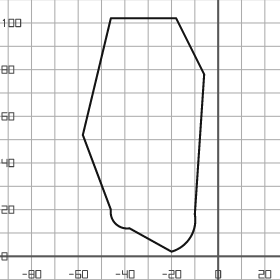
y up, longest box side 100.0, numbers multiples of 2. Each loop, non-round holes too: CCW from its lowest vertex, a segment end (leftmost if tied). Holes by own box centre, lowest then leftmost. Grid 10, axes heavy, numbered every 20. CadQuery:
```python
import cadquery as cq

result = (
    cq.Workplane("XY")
    .moveTo(-20.0, 2.0)
    .threePointArc((-12.0, 8.0), (-10.0, 18.0))
    .lineTo(-6.0, 78.0)
    .lineTo(-18.0, 102.0)
    .lineTo(-46.0, 102.0)
    .lineTo(-58.0, 52.0)
    .lineTo(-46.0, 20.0)
    .threePointArc((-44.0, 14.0), (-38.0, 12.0))
    .close()
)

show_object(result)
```